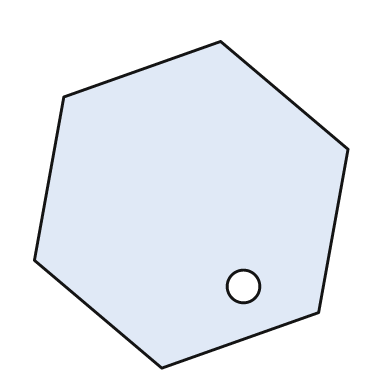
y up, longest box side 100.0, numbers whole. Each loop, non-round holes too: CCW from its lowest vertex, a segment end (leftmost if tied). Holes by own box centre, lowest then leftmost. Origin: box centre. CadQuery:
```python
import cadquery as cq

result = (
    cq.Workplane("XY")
    .moveTo(-9.0, -50.0)
    .lineTo(39.0, -33.0)
    .lineTo(48.0, 17.0)
    .lineTo(9.0, 50.0)
    .lineTo(-39.0, 33.0)
    .lineTo(-48.0, -17.0)
    .close()
    .moveTo(16.0, -25.0)
    .circle(5.0)
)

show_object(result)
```